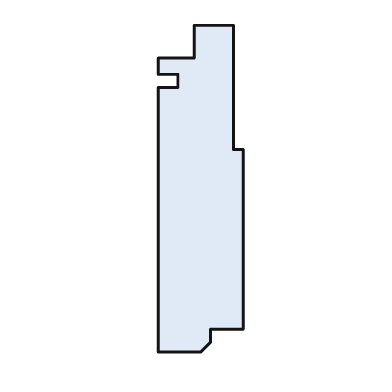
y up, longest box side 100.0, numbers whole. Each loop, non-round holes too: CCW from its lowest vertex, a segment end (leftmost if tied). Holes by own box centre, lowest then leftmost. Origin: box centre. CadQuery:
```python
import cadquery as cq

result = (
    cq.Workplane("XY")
    .moveTo(-13.0, -50.0)
    .lineTo(0.0, -50.0)
    .lineTo(3.0, -47.0)
    .lineTo(3.0, -43.0)
    .lineTo(13.0, -43.0)
    .lineTo(13.0, 12.0)
    .lineTo(10.0, 12.0)
    .lineTo(10.0, 50.0)
    .lineTo(-2.0, 50.0)
    .lineTo(-2.0, 40.0)
    .lineTo(-13.0, 40.0)
    .lineTo(-13.0, 35.0)
    .lineTo(-7.0, 35.0)
    .lineTo(-7.0, 31.0)
    .lineTo(-13.0, 31.0)
    .close()
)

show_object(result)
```